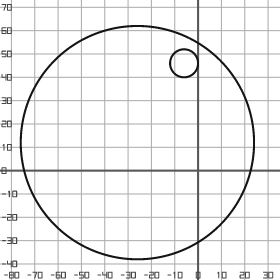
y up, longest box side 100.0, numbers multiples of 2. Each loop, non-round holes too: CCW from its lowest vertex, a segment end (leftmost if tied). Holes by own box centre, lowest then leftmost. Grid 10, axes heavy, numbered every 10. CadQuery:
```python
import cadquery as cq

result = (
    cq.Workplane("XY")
    .moveTo(-26.0, 12.0)
    .circle(50.0)
    .moveTo(-6.0, 46.0)
    .circle(6.0)
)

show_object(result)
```